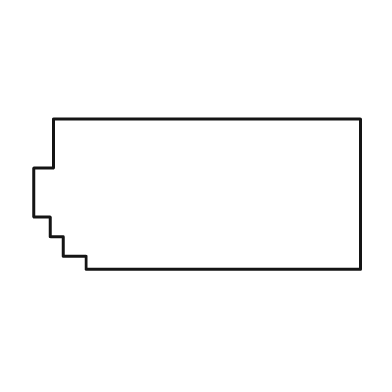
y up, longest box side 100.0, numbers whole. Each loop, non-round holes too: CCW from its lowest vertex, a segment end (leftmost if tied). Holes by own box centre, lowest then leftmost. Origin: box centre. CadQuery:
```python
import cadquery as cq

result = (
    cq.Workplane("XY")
    .moveTo(-34.0, -23.0)
    .lineTo(50.0, -23.0)
    .lineTo(50.0, 23.0)
    .lineTo(-44.0, 23.0)
    .lineTo(-44.0, 8.0)
    .lineTo(-50.0, 8.0)
    .lineTo(-50.0, -7.0)
    .lineTo(-45.0, -7.0)
    .lineTo(-45.0, -13.0)
    .lineTo(-41.0, -13.0)
    .lineTo(-41.0, -19.0)
    .lineTo(-34.0, -19.0)
    .close()
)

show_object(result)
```